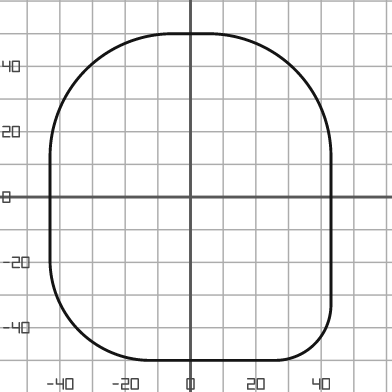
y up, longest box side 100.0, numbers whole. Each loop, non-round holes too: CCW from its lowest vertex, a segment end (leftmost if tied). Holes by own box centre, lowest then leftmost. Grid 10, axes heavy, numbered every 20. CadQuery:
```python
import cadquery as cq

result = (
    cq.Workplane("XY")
    .moveTo(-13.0, -50.0)
    .lineTo(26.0, -50.0)
    .threePointArc((38.0, -45.0), (43.0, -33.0))
    .lineTo(43.0, 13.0)
    .threePointArc((32.0, 39.0), (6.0, 50.0))
    .lineTo(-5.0, 50.0)
    .threePointArc((-32.0, 39.0), (-43.0, 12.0))
    .lineTo(-43.0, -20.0)
    .threePointArc((-34.0, -41.0), (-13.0, -50.0))
    .close()
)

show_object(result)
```